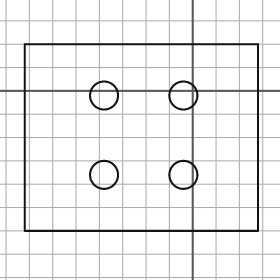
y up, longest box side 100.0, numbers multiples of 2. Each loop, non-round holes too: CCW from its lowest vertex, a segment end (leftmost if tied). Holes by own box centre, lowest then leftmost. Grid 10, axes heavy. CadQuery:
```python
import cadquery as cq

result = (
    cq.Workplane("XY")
    .moveTo(-72.0, -60.0)
    .lineTo(28.0, -60.0)
    .lineTo(28.0, 20.0)
    .lineTo(-72.0, 20.0)
    .close()
    .moveTo(-38.0, -36.0)
    .circle(6.0)
    .moveTo(-4.0, -36.0)
    .circle(6.0)
    .moveTo(-38.0, -2.0)
    .circle(6.0)
    .moveTo(-4.0, -2.0)
    .circle(6.0)
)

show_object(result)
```